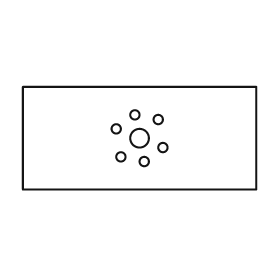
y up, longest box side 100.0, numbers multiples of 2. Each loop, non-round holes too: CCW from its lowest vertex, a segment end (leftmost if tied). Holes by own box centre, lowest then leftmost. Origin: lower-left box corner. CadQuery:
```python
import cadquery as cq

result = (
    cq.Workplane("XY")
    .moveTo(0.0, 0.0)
    .lineTo(100.0, 0.0)
    .lineTo(100.0, 44.0)
    .lineTo(0.0, 44.0)
    .close()
    .moveTo(52.0, 12.0)
    .circle(2.0)
    .moveTo(42.0, 14.0)
    .circle(2.0)
    .moveTo(60.0, 18.0)
    .circle(2.0)
    .moveTo(50.0, 22.0)
    .circle(4.0)
    .moveTo(40.0, 26.0)
    .circle(2.0)
    .moveTo(58.0, 30.0)
    .circle(2.0)
    .moveTo(48.0, 32.0)
    .circle(2.0)
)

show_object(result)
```